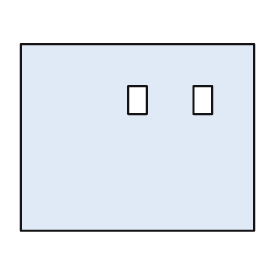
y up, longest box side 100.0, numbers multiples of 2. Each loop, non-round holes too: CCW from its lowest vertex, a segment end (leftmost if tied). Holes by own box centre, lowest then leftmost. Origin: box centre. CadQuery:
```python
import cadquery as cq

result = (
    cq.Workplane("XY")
    .moveTo(-50.0, -40.0)
    .lineTo(50.0, -40.0)
    .lineTo(50.0, 40.0)
    .lineTo(-50.0, 40.0)
    .close()
    .moveTo(-4.0, 10.0)
    .lineTo(4.0, 10.0)
    .lineTo(4.0, 22.0)
    .lineTo(-4.0, 22.0)
    .close()
    .moveTo(24.0, 10.0)
    .lineTo(32.0, 10.0)
    .lineTo(32.0, 22.0)
    .lineTo(24.0, 22.0)
    .close()
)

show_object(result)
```